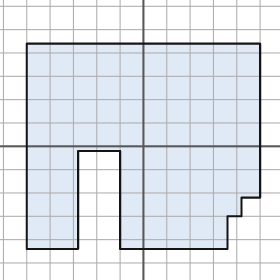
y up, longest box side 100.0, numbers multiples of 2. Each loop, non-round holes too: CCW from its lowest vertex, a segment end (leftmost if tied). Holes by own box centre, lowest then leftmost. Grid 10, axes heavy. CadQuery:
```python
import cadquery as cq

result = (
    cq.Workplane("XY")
    .moveTo(-50.0, -44.0)
    .lineTo(-28.0, -44.0)
    .lineTo(-28.0, -2.0)
    .lineTo(-10.0, -2.0)
    .lineTo(-10.0, -44.0)
    .lineTo(36.0, -44.0)
    .lineTo(36.0, -30.0)
    .lineTo(42.0, -30.0)
    .lineTo(42.0, -22.0)
    .lineTo(50.0, -22.0)
    .lineTo(50.0, 44.0)
    .lineTo(-50.0, 44.0)
    .close()
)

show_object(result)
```